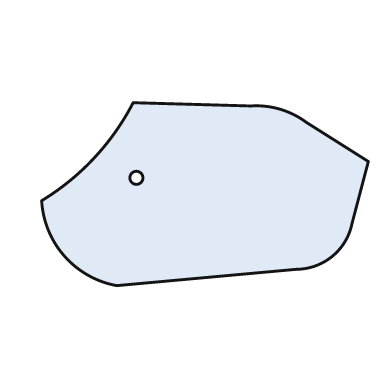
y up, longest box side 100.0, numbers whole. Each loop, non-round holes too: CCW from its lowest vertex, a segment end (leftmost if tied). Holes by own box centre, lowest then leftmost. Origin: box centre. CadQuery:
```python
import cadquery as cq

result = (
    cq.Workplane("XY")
    .moveTo(-27.0, -28.0)
    .lineTo(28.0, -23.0)
    .threePointArc((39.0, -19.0), (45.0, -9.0))
    .lineTo(50.0, 10.0)
    .lineTo(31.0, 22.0)
    .threePointArc((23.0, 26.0), (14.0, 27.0))
    .lineTo(-22.0, 28.0)
    .threePointArc((-34.0, 11.0), (-50.0, -2.0))
    .threePointArc((-43.0, -19.0), (-27.0, -28.0))
    .close()
    .moveTo(-21.0, 5.0)
    .circle(2.0)
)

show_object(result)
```